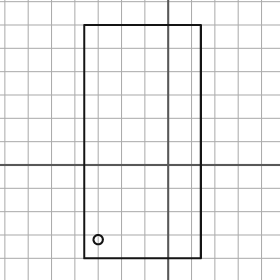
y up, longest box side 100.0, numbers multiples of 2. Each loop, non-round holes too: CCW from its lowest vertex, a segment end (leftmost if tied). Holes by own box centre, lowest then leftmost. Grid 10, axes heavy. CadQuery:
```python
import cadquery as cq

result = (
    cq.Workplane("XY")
    .moveTo(-36.0, -40.0)
    .lineTo(14.0, -40.0)
    .lineTo(14.0, 60.0)
    .lineTo(-36.0, 60.0)
    .close()
    .moveTo(-30.0, -32.0)
    .circle(2.0)
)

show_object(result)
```